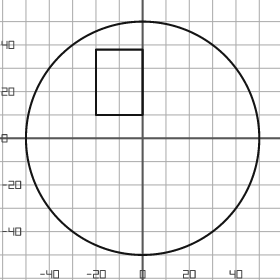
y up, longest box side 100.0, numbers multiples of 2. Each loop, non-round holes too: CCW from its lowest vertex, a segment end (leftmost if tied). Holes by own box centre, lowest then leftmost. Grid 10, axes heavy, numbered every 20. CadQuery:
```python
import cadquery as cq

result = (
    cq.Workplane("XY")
    .moveTo(0.0, 0.0)
    .circle(50.0)
    .moveTo(-20.0, 10.0)
    .lineTo(0.0, 10.0)
    .lineTo(0.0, 38.0)
    .lineTo(-20.0, 38.0)
    .close()
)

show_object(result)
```